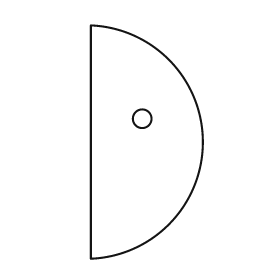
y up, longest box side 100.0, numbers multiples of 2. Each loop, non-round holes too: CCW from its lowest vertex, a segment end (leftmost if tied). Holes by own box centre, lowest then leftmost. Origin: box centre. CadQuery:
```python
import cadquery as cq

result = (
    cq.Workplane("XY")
    .moveTo(-24.0, -50.0)
    .threePointArc((24.0, 0.0), (-24.0, 50.0))
    .close()
    .moveTo(-2.0, 10.0)
    .circle(4.0)
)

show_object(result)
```